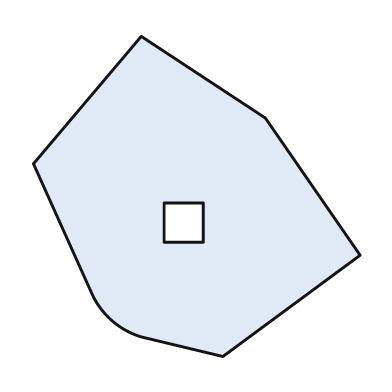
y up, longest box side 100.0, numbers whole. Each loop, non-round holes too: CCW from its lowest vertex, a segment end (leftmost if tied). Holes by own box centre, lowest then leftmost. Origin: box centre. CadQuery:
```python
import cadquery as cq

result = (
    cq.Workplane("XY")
    .moveTo(8.0, -49.0)
    .lineTo(50.0, -18.0)
    .lineTo(21.0, 24.0)
    .lineTo(-17.0, 49.0)
    .lineTo(-50.0, 10.0)
    .lineTo(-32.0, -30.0)
    .threePointArc((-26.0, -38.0), (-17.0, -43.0))
    .close()
    .moveTo(-10.0, -14.0)
    .lineTo(2.0, -14.0)
    .lineTo(2.0, -2.0)
    .lineTo(-10.0, -2.0)
    .close()
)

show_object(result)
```